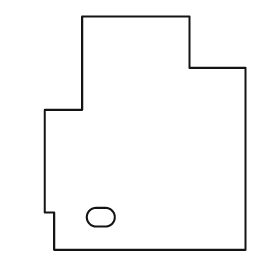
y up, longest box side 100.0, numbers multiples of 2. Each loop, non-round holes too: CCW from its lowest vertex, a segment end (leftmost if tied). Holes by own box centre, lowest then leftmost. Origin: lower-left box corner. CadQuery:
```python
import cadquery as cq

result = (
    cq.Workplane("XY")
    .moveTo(4.0, 0.0)
    .lineTo(86.0, 0.0)
    .lineTo(86.0, 78.0)
    .lineTo(62.0, 78.0)
    .lineTo(62.0, 100.0)
    .lineTo(16.0, 100.0)
    .lineTo(16.0, 60.0)
    .lineTo(0.0, 60.0)
    .lineTo(0.0, 16.0)
    .lineTo(4.0, 16.0)
    .close()
    .moveTo(22.0, 10.0)
    .lineTo(26.0, 10.0)
    .threePointArc((30.0, 14.0), (26.0, 18.0))
    .lineTo(22.0, 18.0)
    .threePointArc((18.0, 14.0), (22.0, 10.0))
    .close()
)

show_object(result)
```